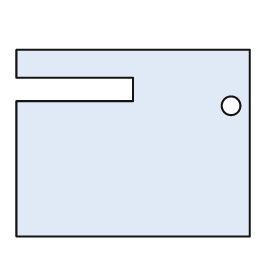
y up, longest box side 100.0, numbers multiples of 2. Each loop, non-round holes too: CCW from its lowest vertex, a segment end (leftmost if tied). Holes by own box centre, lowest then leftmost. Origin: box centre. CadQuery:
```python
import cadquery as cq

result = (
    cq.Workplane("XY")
    .moveTo(-50.0, -40.0)
    .lineTo(50.0, -40.0)
    .lineTo(50.0, 40.0)
    .lineTo(-50.0, 40.0)
    .lineTo(-50.0, 28.0)
    .lineTo(0.0, 28.0)
    .lineTo(0.0, 18.0)
    .lineTo(-50.0, 18.0)
    .close()
    .moveTo(42.0, 16.0)
    .circle(4.0)
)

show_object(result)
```